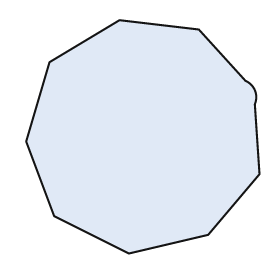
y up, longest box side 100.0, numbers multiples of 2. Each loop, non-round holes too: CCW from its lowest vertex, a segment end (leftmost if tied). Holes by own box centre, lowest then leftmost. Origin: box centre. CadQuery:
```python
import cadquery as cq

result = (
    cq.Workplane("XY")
    .moveTo(-6.0, -50.0)
    .lineTo(28.0, -42.0)
    .lineTo(50.0, -16.0)
    .lineTo(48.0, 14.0)
    .threePointArc((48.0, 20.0), (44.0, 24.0))
    .lineTo(24.0, 46.0)
    .lineTo(-10.0, 50.0)
    .lineTo(-40.0, 32.0)
    .lineTo(-50.0, -2.0)
    .lineTo(-38.0, -34.0)
    .close()
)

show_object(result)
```